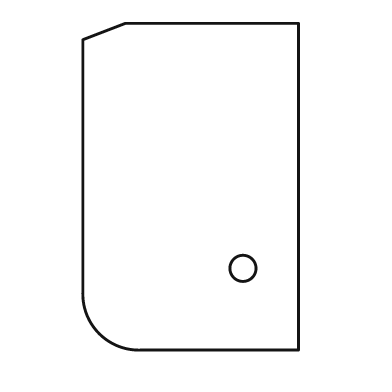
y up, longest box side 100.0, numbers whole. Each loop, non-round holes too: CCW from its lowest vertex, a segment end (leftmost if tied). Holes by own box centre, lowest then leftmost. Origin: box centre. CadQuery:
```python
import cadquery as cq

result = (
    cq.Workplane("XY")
    .moveTo(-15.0, -50.0)
    .lineTo(33.0, -50.0)
    .lineTo(33.0, 50.0)
    .lineTo(-20.0, 50.0)
    .lineTo(-33.0, 45.0)
    .lineTo(-33.0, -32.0)
    .threePointArc((-28.0, -45.0), (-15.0, -50.0))
    .close()
    .moveTo(16.0, -25.0)
    .circle(4.0)
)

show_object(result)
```